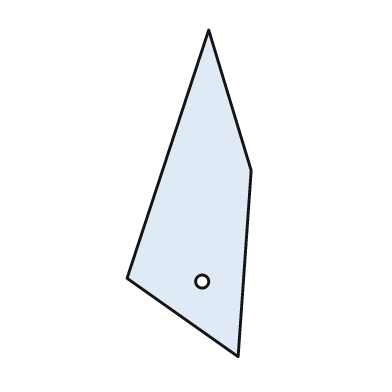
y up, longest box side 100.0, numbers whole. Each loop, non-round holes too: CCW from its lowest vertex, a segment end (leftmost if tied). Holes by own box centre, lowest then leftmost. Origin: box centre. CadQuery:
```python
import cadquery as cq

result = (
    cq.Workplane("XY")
    .moveTo(15.0, -50.0)
    .lineTo(19.0, 7.0)
    .lineTo(6.0, 50.0)
    .lineTo(-19.0, -26.0)
    .close()
    .moveTo(4.0, -27.0)
    .circle(2.0)
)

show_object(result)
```